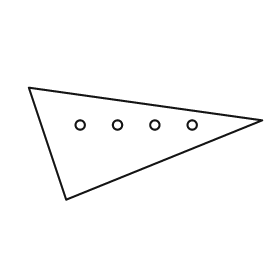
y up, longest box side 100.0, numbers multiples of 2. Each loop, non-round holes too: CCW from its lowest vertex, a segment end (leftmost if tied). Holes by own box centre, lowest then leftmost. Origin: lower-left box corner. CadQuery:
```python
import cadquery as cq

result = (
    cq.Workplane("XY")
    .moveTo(16.0, 0.0)
    .lineTo(100.0, 34.0)
    .lineTo(0.0, 48.0)
    .close()
    .moveTo(22.0, 32.0)
    .circle(2.0)
    .moveTo(38.0, 32.0)
    .circle(2.0)
    .moveTo(54.0, 32.0)
    .circle(2.0)
    .moveTo(70.0, 32.0)
    .circle(2.0)
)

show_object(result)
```